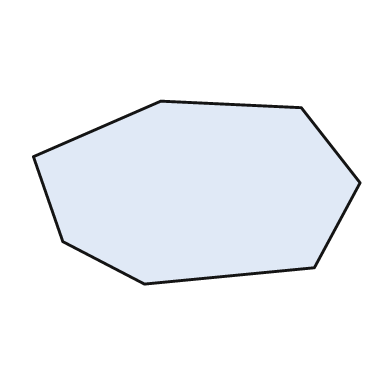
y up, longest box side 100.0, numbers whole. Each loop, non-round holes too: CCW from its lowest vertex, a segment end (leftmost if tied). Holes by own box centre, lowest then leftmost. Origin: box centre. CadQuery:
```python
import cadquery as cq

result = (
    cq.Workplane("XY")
    .moveTo(-16.0, -28.0)
    .lineTo(36.0, -23.0)
    .lineTo(50.0, 3.0)
    .lineTo(32.0, 26.0)
    .lineTo(-11.0, 28.0)
    .lineTo(-50.0, 11.0)
    .lineTo(-41.0, -15.0)
    .close()
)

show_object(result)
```